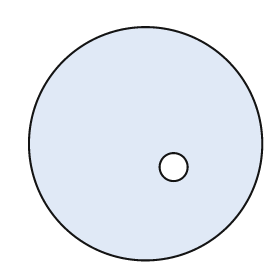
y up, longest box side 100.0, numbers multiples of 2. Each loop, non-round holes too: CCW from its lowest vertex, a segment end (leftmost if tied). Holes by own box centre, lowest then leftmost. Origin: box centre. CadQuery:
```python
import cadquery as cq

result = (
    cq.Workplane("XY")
    .moveTo(0.0, 0.0)
    .circle(50.0)
    .moveTo(12.0, -10.0)
    .circle(6.0)
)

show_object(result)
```